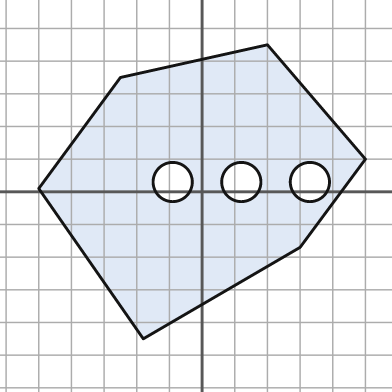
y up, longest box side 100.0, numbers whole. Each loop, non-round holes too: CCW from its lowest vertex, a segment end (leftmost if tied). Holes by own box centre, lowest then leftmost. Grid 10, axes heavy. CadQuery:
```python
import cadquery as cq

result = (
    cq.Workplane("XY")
    .moveTo(-18.0, -45.0)
    .lineTo(30.0, -17.0)
    .lineTo(50.0, 10.0)
    .lineTo(20.0, 45.0)
    .lineTo(-25.0, 35.0)
    .lineTo(-50.0, 1.0)
    .close()
    .moveTo(-9.0, 3.0)
    .circle(6.0)
    .moveTo(12.0, 3.0)
    .circle(6.0)
    .moveTo(33.0, 3.0)
    .circle(6.0)
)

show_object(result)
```